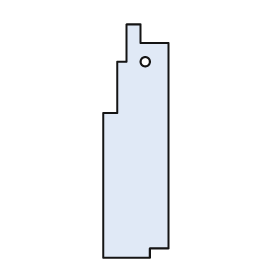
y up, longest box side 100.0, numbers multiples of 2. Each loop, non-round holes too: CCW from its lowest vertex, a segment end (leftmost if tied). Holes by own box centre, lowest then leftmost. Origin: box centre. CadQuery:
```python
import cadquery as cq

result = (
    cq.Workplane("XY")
    .moveTo(-14.0, -50.0)
    .lineTo(6.0, -50.0)
    .lineTo(6.0, -46.0)
    .lineTo(14.0, -46.0)
    .lineTo(14.0, 42.0)
    .lineTo(2.0, 42.0)
    .lineTo(2.0, 50.0)
    .lineTo(-4.0, 50.0)
    .lineTo(-4.0, 34.0)
    .lineTo(-8.0, 34.0)
    .lineTo(-8.0, 12.0)
    .lineTo(-14.0, 12.0)
    .close()
    .moveTo(4.0, 34.0)
    .circle(2.0)
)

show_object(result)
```